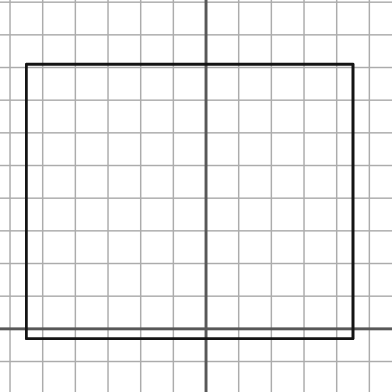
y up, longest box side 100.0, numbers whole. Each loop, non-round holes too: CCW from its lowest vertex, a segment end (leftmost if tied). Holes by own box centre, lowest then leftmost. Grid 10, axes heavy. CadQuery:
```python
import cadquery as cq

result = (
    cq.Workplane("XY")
    .moveTo(-55.0, -3.0)
    .lineTo(45.0, -3.0)
    .lineTo(45.0, 81.0)
    .lineTo(-55.0, 81.0)
    .close()
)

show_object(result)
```